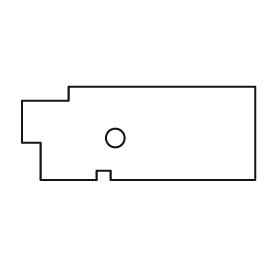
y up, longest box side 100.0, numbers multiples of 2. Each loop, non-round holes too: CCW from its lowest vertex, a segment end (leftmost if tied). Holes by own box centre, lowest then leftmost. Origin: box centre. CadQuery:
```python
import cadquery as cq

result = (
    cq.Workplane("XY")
    .moveTo(-42.0, -20.0)
    .lineTo(-18.0, -20.0)
    .lineTo(-18.0, -16.0)
    .lineTo(-12.0, -16.0)
    .lineTo(-12.0, -20.0)
    .lineTo(50.0, -20.0)
    .lineTo(50.0, 20.0)
    .lineTo(-30.0, 20.0)
    .lineTo(-30.0, 14.0)
    .lineTo(-50.0, 14.0)
    .lineTo(-50.0, -4.0)
    .lineTo(-42.0, -4.0)
    .close()
    .moveTo(-10.0, -2.0)
    .circle(4.0)
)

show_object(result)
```